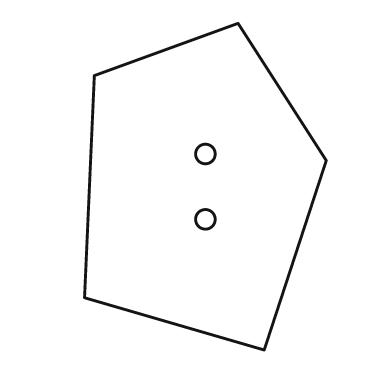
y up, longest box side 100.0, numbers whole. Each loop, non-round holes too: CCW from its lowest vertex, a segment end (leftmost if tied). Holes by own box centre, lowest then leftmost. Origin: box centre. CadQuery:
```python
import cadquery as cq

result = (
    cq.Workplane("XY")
    .moveTo(18.0, -50.0)
    .lineTo(37.0, 8.0)
    .lineTo(10.0, 50.0)
    .lineTo(-34.0, 34.0)
    .lineTo(-37.0, -34.0)
    .close()
    .moveTo(0.0, -10.0)
    .circle(3.0)
    .moveTo(0.0, 10.0)
    .circle(3.0)
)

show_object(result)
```